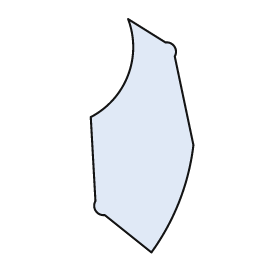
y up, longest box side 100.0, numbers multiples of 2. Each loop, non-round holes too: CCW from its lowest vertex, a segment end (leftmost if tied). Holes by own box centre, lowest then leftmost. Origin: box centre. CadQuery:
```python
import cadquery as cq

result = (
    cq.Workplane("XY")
    .moveTo(4.0, -50.0)
    .threePointArc((16.0, -28.0), (22.0, -4.0))
    .lineTo(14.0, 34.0)
    .threePointArc((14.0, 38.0), (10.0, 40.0))
    .lineTo(-6.0, 50.0)
    .threePointArc((-6.0, 26.0), (-22.0, 8.0))
    .lineTo(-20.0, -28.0)
    .threePointArc((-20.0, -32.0), (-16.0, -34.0))
    .close()
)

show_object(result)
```